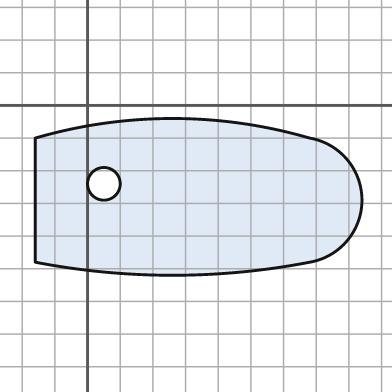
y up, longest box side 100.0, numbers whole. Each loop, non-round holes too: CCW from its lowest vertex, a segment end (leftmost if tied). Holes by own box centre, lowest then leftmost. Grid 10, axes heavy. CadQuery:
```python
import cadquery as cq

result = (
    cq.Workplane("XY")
    .moveTo(-16.0, -48.0)
    .threePointArc((26.0, -52.0), (68.0, -48.0))
    .threePointArc((84.0, -29.0), (68.0, -10.0))
    .threePointArc((26.0, -4.0), (-16.0, -10.0))
    .close()
    .moveTo(5.0, -24.0)
    .circle(5.0)
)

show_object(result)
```